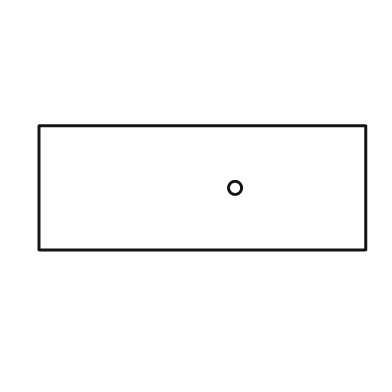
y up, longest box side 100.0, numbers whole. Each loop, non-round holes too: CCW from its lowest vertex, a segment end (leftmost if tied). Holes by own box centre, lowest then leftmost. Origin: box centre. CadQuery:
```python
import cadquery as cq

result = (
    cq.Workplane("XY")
    .moveTo(-50.0, -19.0)
    .lineTo(50.0, -19.0)
    .lineTo(50.0, 19.0)
    .lineTo(-50.0, 19.0)
    .close()
    .moveTo(10.0, 0.0)
    .circle(2.0)
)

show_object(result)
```